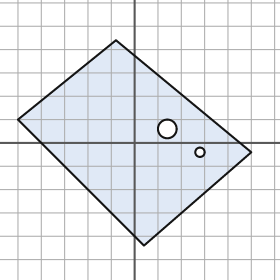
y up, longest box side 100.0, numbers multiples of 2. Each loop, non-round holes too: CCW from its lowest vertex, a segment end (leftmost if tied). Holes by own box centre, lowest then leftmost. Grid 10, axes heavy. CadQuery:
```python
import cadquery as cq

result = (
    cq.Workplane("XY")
    .moveTo(4.0, -44.0)
    .lineTo(50.0, -4.0)
    .lineTo(-8.0, 44.0)
    .lineTo(-50.0, 10.0)
    .close()
    .moveTo(28.0, -4.0)
    .circle(2.0)
    .moveTo(14.0, 6.0)
    .circle(4.0)
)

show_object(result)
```